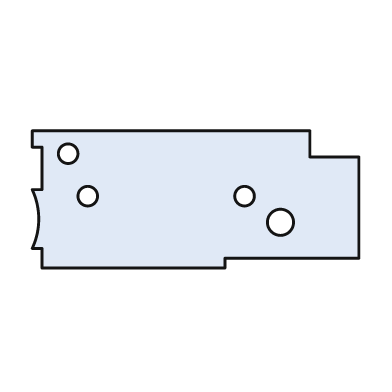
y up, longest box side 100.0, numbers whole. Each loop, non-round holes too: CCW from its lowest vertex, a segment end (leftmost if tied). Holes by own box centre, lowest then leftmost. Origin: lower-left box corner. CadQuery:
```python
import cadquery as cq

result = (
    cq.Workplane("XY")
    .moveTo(3.0, 0.0)
    .lineTo(59.0, 0.0)
    .lineTo(59.0, 3.0)
    .lineTo(100.0, 3.0)
    .lineTo(100.0, 34.0)
    .lineTo(85.0, 34.0)
    .lineTo(85.0, 42.0)
    .lineTo(0.0, 42.0)
    .lineTo(0.0, 37.0)
    .lineTo(3.0, 37.0)
    .lineTo(3.0, 24.0)
    .lineTo(0.0, 24.0)
    .threePointArc((2.0, 15.0), (0.0, 6.0))
    .lineTo(3.0, 6.0)
    .close()
    .moveTo(76.0, 14.0)
    .circle(4.0)
    .moveTo(17.0, 22.0)
    .circle(3.0)
    .moveTo(65.0, 22.0)
    .circle(3.0)
    .moveTo(11.0, 35.0)
    .circle(3.0)
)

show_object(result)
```